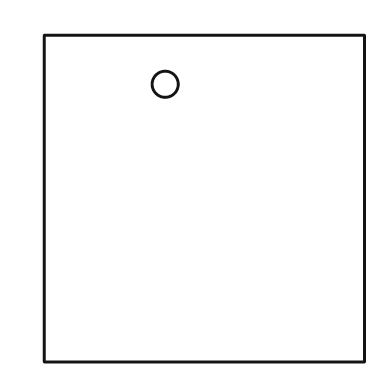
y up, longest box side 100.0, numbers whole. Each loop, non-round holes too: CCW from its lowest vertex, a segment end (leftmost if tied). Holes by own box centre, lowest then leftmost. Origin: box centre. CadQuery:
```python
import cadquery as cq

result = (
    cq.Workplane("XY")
    .moveTo(-49.0, -50.0)
    .lineTo(49.0, -50.0)
    .lineTo(49.0, 50.0)
    .lineTo(-49.0, 50.0)
    .close()
    .moveTo(-12.0, 35.0)
    .circle(4.0)
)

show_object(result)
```